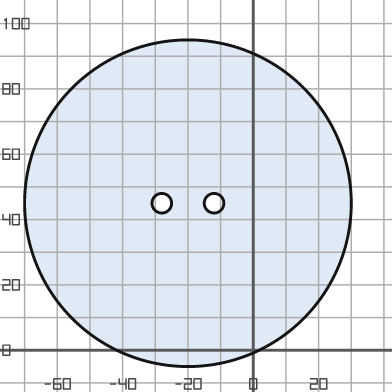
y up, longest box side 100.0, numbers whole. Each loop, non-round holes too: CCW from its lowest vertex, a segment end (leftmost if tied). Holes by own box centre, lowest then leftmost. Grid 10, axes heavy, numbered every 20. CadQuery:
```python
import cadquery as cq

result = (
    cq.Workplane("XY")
    .moveTo(-20.0, 45.0)
    .circle(50.0)
    .moveTo(-28.0, 45.0)
    .circle(3.0)
    .moveTo(-12.0, 45.0)
    .circle(3.0)
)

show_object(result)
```